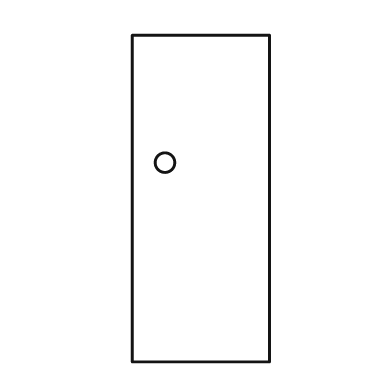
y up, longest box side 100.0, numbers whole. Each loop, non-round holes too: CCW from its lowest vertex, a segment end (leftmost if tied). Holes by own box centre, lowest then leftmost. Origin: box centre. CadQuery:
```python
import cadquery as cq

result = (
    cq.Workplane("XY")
    .moveTo(-21.0, -50.0)
    .lineTo(21.0, -50.0)
    .lineTo(21.0, 50.0)
    .lineTo(-21.0, 50.0)
    .close()
    .moveTo(-11.0, 11.0)
    .circle(3.0)
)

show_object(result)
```